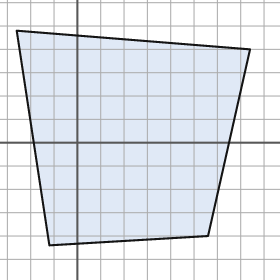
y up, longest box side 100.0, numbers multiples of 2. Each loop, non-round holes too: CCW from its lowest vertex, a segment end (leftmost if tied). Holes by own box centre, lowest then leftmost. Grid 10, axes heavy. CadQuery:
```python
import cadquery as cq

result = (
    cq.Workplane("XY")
    .moveTo(-12.0, -44.0)
    .lineTo(56.0, -40.0)
    .lineTo(74.0, 40.0)
    .lineTo(-26.0, 48.0)
    .close()
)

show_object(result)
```